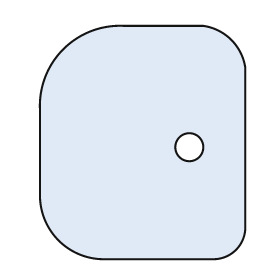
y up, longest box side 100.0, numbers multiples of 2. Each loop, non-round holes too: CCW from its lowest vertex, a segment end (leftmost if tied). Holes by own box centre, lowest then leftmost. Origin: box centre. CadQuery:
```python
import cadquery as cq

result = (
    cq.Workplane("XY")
    .moveTo(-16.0, -50.0)
    .lineTo(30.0, -50.0)
    .threePointArc((40.0, -46.0), (44.0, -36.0))
    .lineTo(44.0, 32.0)
    .threePointArc((38.0, 44.0), (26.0, 50.0))
    .lineTo(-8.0, 50.0)
    .threePointArc((-34.0, 40.0), (-44.0, 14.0))
    .lineTo(-44.0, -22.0)
    .threePointArc((-36.0, -42.0), (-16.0, -50.0))
    .close()
    .moveTo(20.0, -2.0)
    .circle(6.0)
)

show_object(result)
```